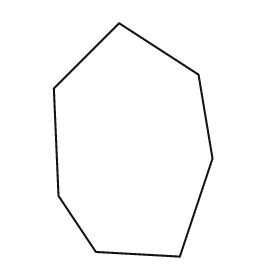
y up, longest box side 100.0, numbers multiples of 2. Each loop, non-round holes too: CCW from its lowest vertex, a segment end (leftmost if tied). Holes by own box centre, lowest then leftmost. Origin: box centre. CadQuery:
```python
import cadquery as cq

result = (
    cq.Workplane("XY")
    .moveTo(20.0, -50.0)
    .lineTo(34.0, -8.0)
    .lineTo(28.0, 28.0)
    .lineTo(-6.0, 50.0)
    .lineTo(-34.0, 22.0)
    .lineTo(-32.0, -24.0)
    .lineTo(-16.0, -48.0)
    .close()
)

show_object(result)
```